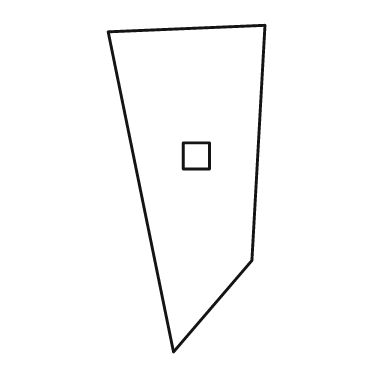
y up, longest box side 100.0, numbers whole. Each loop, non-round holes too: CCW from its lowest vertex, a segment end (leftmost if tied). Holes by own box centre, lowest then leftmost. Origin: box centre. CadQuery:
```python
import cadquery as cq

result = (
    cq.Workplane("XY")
    .moveTo(-4.0, -50.0)
    .lineTo(20.0, -22.0)
    .lineTo(24.0, 50.0)
    .lineTo(-24.0, 48.0)
    .close()
    .moveTo(-1.0, 6.0)
    .lineTo(7.0, 6.0)
    .lineTo(7.0, 14.0)
    .lineTo(-1.0, 14.0)
    .close()
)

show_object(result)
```